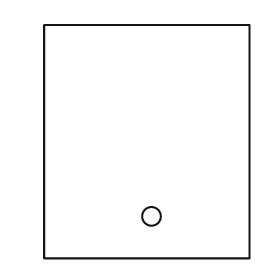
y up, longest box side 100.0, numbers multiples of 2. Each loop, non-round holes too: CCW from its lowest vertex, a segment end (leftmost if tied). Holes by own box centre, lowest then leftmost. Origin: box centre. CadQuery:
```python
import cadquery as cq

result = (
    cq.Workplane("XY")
    .moveTo(-44.0, -50.0)
    .lineTo(44.0, -50.0)
    .lineTo(44.0, 50.0)
    .lineTo(-44.0, 50.0)
    .close()
    .moveTo(2.0, -32.0)
    .circle(4.0)
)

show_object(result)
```